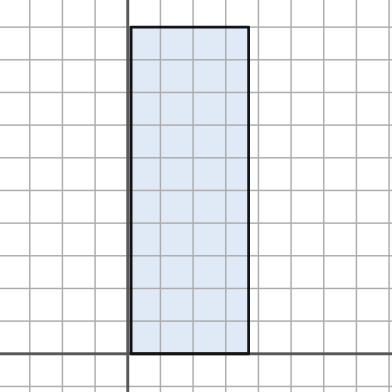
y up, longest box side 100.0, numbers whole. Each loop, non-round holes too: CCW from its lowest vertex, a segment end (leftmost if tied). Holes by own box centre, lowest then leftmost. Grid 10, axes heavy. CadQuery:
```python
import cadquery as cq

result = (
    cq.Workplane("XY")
    .moveTo(1.0, 0.0)
    .lineTo(37.0, 0.0)
    .lineTo(37.0, 100.0)
    .lineTo(1.0, 100.0)
    .close()
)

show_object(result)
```